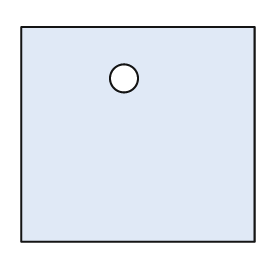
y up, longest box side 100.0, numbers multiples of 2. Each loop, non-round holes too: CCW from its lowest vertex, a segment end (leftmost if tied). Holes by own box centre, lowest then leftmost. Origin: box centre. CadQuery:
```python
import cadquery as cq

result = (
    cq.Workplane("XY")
    .moveTo(-50.0, -46.0)
    .lineTo(50.0, -46.0)
    .lineTo(50.0, 46.0)
    .lineTo(-50.0, 46.0)
    .close()
    .moveTo(-6.0, 24.0)
    .circle(6.0)
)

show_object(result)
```